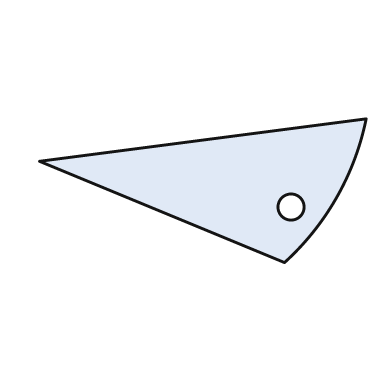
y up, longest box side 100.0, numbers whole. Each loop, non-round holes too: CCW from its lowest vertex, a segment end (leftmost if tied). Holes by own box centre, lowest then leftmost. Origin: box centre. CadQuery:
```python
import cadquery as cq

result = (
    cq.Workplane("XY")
    .moveTo(25.0, -22.0)
    .threePointArc((41.0, -2.0), (50.0, 22.0))
    .lineTo(-50.0, 9.0)
    .close()
    .moveTo(27.0, -5.0)
    .circle(4.0)
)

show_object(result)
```